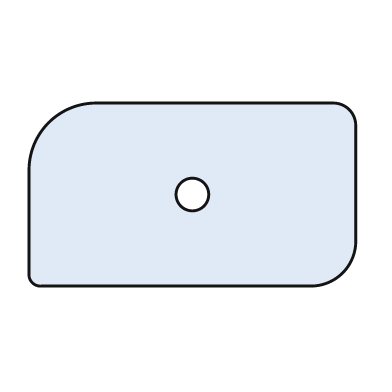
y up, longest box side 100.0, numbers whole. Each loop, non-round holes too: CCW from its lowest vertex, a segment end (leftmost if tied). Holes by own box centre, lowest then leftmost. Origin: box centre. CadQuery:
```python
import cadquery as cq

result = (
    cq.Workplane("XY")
    .moveTo(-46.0, -28.0)
    .lineTo(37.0, -28.0)
    .threePointArc((46.0, -24.0), (50.0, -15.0))
    .lineTo(50.0, 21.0)
    .threePointArc((48.0, 26.0), (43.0, 28.0))
    .lineTo(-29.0, 28.0)
    .threePointArc((-44.0, 22.0), (-50.0, 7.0))
    .lineTo(-50.0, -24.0)
    .threePointArc((-49.0, -27.0), (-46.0, -28.0))
    .close()
    .moveTo(0.0, 0.0)
    .circle(5.0)
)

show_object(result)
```